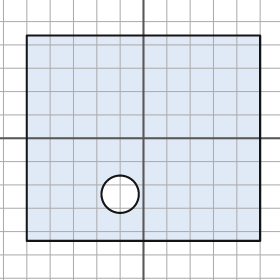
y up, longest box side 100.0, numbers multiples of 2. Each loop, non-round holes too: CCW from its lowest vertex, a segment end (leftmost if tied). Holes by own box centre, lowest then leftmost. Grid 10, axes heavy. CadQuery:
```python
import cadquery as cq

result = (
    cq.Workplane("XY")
    .moveTo(-50.0, -44.0)
    .lineTo(50.0, -44.0)
    .lineTo(50.0, 44.0)
    .lineTo(-50.0, 44.0)
    .close()
    .moveTo(-10.0, -24.0)
    .circle(8.0)
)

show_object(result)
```